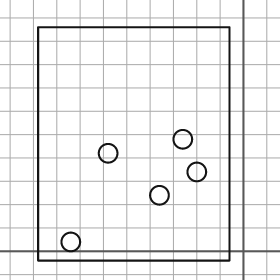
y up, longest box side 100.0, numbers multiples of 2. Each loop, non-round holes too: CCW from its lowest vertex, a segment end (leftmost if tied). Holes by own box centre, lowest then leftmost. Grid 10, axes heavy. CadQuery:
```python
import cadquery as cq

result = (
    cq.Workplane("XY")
    .moveTo(-88.0, -4.0)
    .lineTo(-6.0, -4.0)
    .lineTo(-6.0, 96.0)
    .lineTo(-88.0, 96.0)
    .close()
    .moveTo(-74.0, 4.0)
    .circle(4.0)
    .moveTo(-36.0, 24.0)
    .circle(4.0)
    .moveTo(-20.0, 34.0)
    .circle(4.0)
    .moveTo(-58.0, 42.0)
    .circle(4.0)
    .moveTo(-26.0, 48.0)
    .circle(4.0)
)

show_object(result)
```